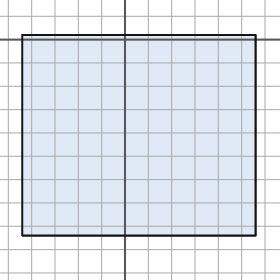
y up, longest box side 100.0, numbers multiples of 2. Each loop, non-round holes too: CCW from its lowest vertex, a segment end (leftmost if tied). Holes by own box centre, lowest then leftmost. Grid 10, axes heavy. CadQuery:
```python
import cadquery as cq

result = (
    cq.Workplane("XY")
    .moveTo(-44.0, -84.0)
    .lineTo(56.0, -84.0)
    .lineTo(56.0, 2.0)
    .lineTo(-44.0, 2.0)
    .close()
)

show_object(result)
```